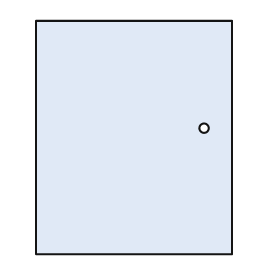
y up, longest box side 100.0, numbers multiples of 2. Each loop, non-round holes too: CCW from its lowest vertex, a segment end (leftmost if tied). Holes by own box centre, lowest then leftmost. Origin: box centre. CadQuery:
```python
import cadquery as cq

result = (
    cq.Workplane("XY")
    .moveTo(-42.0, -50.0)
    .lineTo(42.0, -50.0)
    .lineTo(42.0, 50.0)
    .lineTo(-42.0, 50.0)
    .close()
    .moveTo(30.0, 4.0)
    .circle(2.0)
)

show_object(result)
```